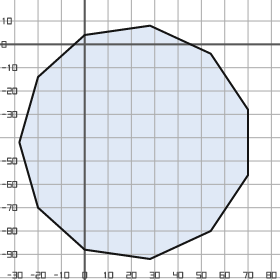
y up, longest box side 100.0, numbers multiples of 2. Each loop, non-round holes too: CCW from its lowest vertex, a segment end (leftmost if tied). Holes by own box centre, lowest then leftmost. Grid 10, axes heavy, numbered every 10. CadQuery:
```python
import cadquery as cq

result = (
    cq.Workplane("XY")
    .moveTo(28.0, -92.0)
    .lineTo(54.0, -80.0)
    .lineTo(70.0, -56.0)
    .lineTo(70.0, -28.0)
    .lineTo(54.0, -4.0)
    .lineTo(28.0, 8.0)
    .lineTo(0.0, 4.0)
    .lineTo(-20.0, -14.0)
    .lineTo(-28.0, -42.0)
    .lineTo(-20.0, -70.0)
    .lineTo(0.0, -88.0)
    .close()
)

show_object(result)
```